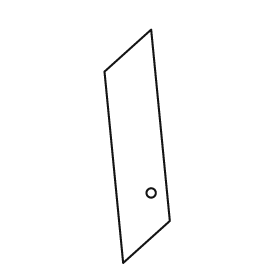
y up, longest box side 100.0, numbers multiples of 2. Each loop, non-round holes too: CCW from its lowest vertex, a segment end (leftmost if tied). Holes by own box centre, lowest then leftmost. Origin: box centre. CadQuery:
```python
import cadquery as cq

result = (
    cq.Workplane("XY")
    .moveTo(-6.0, -50.0)
    .lineTo(14.0, -32.0)
    .lineTo(6.0, 50.0)
    .lineTo(-14.0, 32.0)
    .close()
    .moveTo(6.0, -20.0)
    .circle(2.0)
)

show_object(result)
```